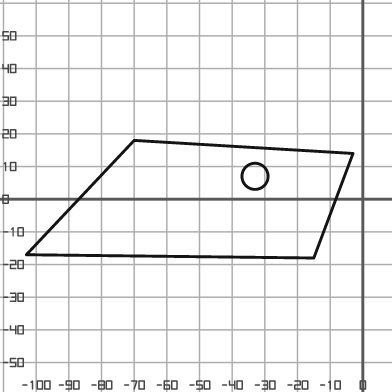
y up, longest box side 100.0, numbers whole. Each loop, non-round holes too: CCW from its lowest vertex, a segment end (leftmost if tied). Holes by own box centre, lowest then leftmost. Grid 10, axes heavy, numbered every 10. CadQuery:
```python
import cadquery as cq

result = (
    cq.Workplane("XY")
    .moveTo(-15.0, -18.0)
    .lineTo(-3.0, 14.0)
    .lineTo(-70.0, 18.0)
    .lineTo(-103.0, -17.0)
    .close()
    .moveTo(-33.0, 7.0)
    .circle(4.0)
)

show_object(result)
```